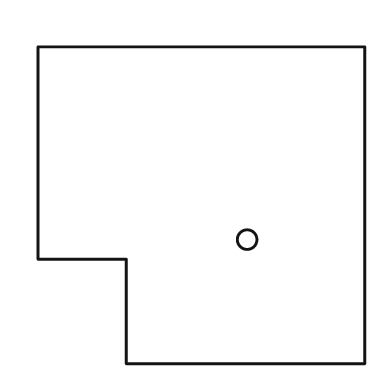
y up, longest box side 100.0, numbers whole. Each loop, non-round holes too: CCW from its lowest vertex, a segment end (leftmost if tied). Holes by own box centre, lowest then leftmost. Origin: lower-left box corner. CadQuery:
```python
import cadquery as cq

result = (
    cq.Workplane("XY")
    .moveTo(27.0, 0.0)
    .lineTo(100.0, 0.0)
    .lineTo(100.0, 97.0)
    .lineTo(0.0, 97.0)
    .lineTo(0.0, 32.0)
    .lineTo(27.0, 32.0)
    .close()
    .moveTo(64.0, 38.0)
    .circle(3.0)
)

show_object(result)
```